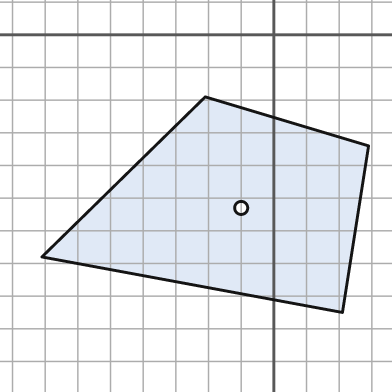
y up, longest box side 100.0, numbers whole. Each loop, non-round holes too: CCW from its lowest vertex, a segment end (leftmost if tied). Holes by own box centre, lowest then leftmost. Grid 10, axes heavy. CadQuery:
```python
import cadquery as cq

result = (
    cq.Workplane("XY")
    .moveTo(21.0, -85.0)
    .lineTo(29.0, -34.0)
    .lineTo(-21.0, -19.0)
    .lineTo(-71.0, -68.0)
    .close()
    .moveTo(-10.0, -53.0)
    .circle(2.0)
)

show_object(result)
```